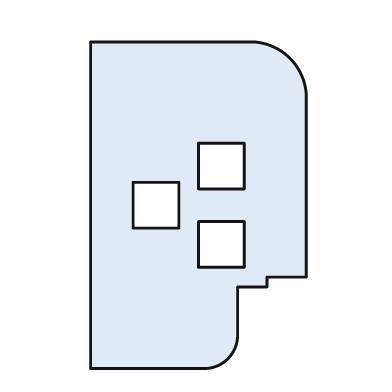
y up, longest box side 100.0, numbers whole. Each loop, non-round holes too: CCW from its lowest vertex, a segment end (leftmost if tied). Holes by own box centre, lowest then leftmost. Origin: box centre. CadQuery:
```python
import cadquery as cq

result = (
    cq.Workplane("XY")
    .moveTo(-33.0, -50.0)
    .lineTo(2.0, -50.0)
    .threePointArc((9.0, -47.0), (12.0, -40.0))
    .lineTo(12.0, -25.0)
    .lineTo(21.0, -25.0)
    .lineTo(21.0, -22.0)
    .lineTo(33.0, -22.0)
    .lineTo(33.0, 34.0)
    .threePointArc((28.0, 45.0), (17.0, 50.0))
    .lineTo(-33.0, 50.0)
    .close()
    .moveTo(0.0, -19.0)
    .lineTo(14.0, -19.0)
    .lineTo(14.0, -5.0)
    .lineTo(0.0, -5.0)
    .close()
    .moveTo(-20.0, -7.0)
    .lineTo(-6.0, -7.0)
    .lineTo(-6.0, 7.0)
    .lineTo(-20.0, 7.0)
    .close()
    .moveTo(0.0, 5.0)
    .lineTo(14.0, 5.0)
    .lineTo(14.0, 19.0)
    .lineTo(0.0, 19.0)
    .close()
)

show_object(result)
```